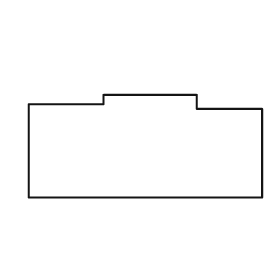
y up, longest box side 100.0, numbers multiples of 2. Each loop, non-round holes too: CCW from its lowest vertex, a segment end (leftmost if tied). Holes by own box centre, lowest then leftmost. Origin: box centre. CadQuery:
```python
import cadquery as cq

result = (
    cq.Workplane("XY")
    .moveTo(-50.0, -22.0)
    .lineTo(50.0, -22.0)
    .lineTo(50.0, 16.0)
    .lineTo(22.0, 16.0)
    .lineTo(22.0, 22.0)
    .lineTo(-18.0, 22.0)
    .lineTo(-18.0, 18.0)
    .lineTo(-50.0, 18.0)
    .close()
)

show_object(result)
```